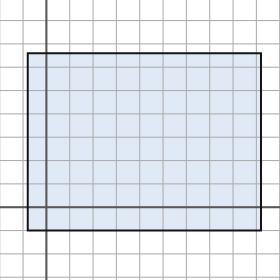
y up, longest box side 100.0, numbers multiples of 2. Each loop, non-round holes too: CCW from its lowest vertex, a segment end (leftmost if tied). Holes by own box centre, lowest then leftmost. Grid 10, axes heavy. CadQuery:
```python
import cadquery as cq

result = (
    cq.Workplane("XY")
    .moveTo(-8.0, -10.0)
    .lineTo(92.0, -10.0)
    .lineTo(92.0, 66.0)
    .lineTo(-8.0, 66.0)
    .close()
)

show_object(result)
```